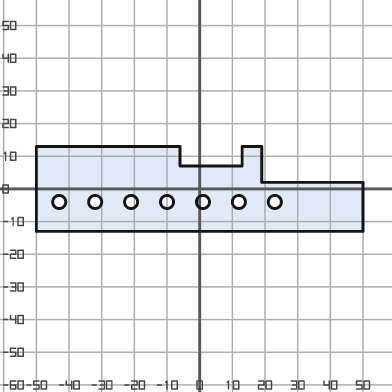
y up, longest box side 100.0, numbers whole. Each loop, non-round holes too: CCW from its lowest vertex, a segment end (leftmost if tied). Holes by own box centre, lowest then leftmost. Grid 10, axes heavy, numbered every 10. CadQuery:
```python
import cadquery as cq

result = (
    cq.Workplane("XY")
    .moveTo(-50.0, -13.0)
    .lineTo(50.0, -13.0)
    .lineTo(50.0, 2.0)
    .lineTo(19.0, 2.0)
    .lineTo(19.0, 13.0)
    .lineTo(13.0, 13.0)
    .lineTo(13.0, 7.0)
    .lineTo(-6.0, 7.0)
    .lineTo(-6.0, 13.0)
    .lineTo(-50.0, 13.0)
    .close()
    .moveTo(-43.0, -4.0)
    .circle(2.0)
    .moveTo(-32.0, -4.0)
    .circle(2.0)
    .moveTo(-21.0, -4.0)
    .circle(2.0)
    .moveTo(-10.0, -4.0)
    .circle(2.0)
    .moveTo(1.0, -4.0)
    .circle(2.0)
    .moveTo(12.0, -4.0)
    .circle(2.0)
    .moveTo(23.0, -4.0)
    .circle(2.0)
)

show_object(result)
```